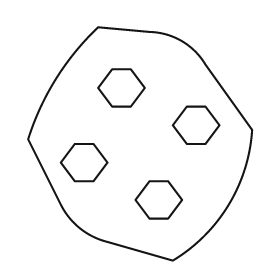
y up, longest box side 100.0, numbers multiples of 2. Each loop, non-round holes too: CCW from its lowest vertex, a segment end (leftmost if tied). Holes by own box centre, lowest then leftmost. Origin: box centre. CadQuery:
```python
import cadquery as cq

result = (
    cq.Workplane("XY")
    .moveTo(14.0, -50.0)
    .threePointArc((38.0, -26.0), (48.0, 6.0))
    .lineTo(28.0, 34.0)
    .threePointArc((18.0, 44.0), (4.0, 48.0))
    .lineTo(-18.0, 50.0)
    .threePointArc((-36.0, 28.0), (-48.0, 2.0))
    .lineTo(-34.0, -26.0)
    .threePointArc((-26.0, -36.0), (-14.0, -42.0))
    .close()
    .moveTo(4.0, -32.0)
    .lineTo(12.0, -32.0)
    .lineTo(18.0, -24.0)
    .lineTo(12.0, -16.0)
    .lineTo(4.0, -16.0)
    .lineTo(-2.0, -24.0)
    .close()
    .moveTo(-28.0, -16.0)
    .lineTo(-20.0, -16.0)
    .lineTo(-14.0, -8.0)
    .lineTo(-20.0, 0.0)
    .lineTo(-28.0, 0.0)
    .lineTo(-34.0, -8.0)
    .close()
    .moveTo(20.0, 0.0)
    .lineTo(28.0, 0.0)
    .lineTo(34.0, 8.0)
    .lineTo(28.0, 16.0)
    .lineTo(20.0, 16.0)
    .lineTo(14.0, 8.0)
    .close()
    .moveTo(-12.0, 16.0)
    .lineTo(-4.0, 16.0)
    .lineTo(2.0, 24.0)
    .lineTo(-4.0, 32.0)
    .lineTo(-12.0, 32.0)
    .lineTo(-18.0, 24.0)
    .close()
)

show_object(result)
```